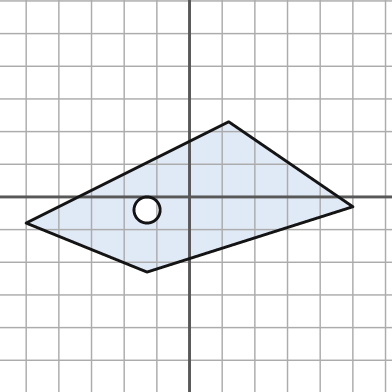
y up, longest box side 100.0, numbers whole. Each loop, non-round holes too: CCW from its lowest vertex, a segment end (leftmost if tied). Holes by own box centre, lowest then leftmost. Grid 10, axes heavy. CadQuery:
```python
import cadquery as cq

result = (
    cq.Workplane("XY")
    .moveTo(-13.0, -23.0)
    .lineTo(50.0, -3.0)
    .lineTo(12.0, 23.0)
    .lineTo(-50.0, -8.0)
    .close()
    .moveTo(-13.0, -4.0)
    .circle(4.0)
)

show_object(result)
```